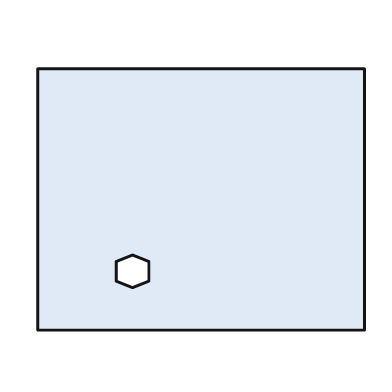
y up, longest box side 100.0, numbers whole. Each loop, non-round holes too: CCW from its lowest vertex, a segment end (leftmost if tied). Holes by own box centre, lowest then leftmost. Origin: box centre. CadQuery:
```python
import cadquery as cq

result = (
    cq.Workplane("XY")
    .moveTo(-50.0, -40.0)
    .lineTo(50.0, -40.0)
    .lineTo(50.0, 40.0)
    .lineTo(-50.0, 40.0)
    .close()
    .moveTo(-21.0, -27.0)
    .lineTo(-16.0, -25.0)
    .lineTo(-16.0, -19.0)
    .lineTo(-21.0, -17.0)
    .lineTo(-26.0, -19.0)
    .lineTo(-26.0, -25.0)
    .close()
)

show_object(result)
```